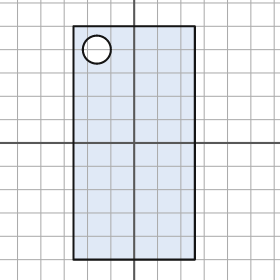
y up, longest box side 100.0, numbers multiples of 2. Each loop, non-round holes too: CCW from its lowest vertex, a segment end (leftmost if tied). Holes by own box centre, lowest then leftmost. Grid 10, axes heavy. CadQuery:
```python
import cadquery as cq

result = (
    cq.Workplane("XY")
    .moveTo(-26.0, -50.0)
    .lineTo(26.0, -50.0)
    .lineTo(26.0, 50.0)
    .lineTo(-26.0, 50.0)
    .close()
    .moveTo(-16.0, 40.0)
    .circle(6.0)
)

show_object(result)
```